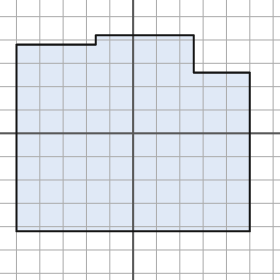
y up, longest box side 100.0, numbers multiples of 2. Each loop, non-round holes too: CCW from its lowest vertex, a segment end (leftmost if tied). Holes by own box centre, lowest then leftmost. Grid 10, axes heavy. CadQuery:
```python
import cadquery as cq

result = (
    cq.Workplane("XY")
    .moveTo(-50.0, -42.0)
    .lineTo(50.0, -42.0)
    .lineTo(50.0, 26.0)
    .lineTo(26.0, 26.0)
    .lineTo(26.0, 42.0)
    .lineTo(-16.0, 42.0)
    .lineTo(-16.0, 38.0)
    .lineTo(-50.0, 38.0)
    .close()
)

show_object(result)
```